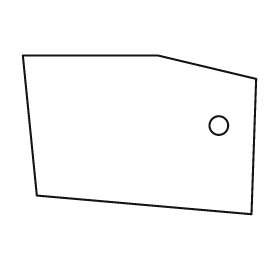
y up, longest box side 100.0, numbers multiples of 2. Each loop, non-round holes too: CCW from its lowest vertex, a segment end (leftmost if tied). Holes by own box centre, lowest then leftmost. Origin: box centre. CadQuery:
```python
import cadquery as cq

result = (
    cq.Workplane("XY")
    .moveTo(48.0, -34.0)
    .lineTo(50.0, 24.0)
    .lineTo(8.0, 34.0)
    .lineTo(-50.0, 34.0)
    .lineTo(-44.0, -26.0)
    .close()
    .moveTo(34.0, 4.0)
    .circle(4.0)
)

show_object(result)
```